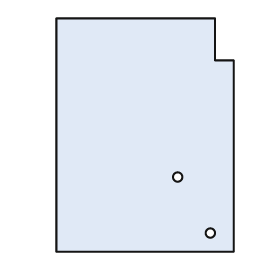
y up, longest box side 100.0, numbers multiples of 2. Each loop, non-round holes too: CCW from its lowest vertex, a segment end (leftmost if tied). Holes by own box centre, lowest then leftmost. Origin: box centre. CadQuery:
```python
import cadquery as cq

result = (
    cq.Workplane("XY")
    .moveTo(-38.0, -50.0)
    .lineTo(38.0, -50.0)
    .lineTo(38.0, 32.0)
    .lineTo(30.0, 32.0)
    .lineTo(30.0, 50.0)
    .lineTo(-38.0, 50.0)
    .close()
    .moveTo(28.0, -42.0)
    .circle(2.0)
    .moveTo(14.0, -18.0)
    .circle(2.0)
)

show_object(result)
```